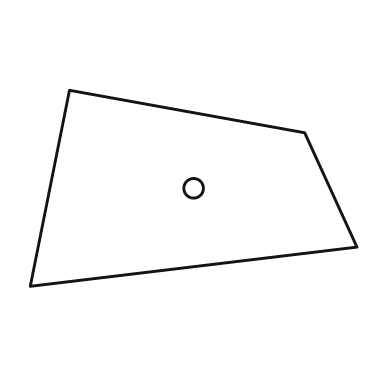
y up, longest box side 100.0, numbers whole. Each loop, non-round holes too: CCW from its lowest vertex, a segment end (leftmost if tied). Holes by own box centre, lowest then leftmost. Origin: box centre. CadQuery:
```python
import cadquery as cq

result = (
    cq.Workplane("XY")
    .moveTo(-50.0, -30.0)
    .lineTo(50.0, -18.0)
    .lineTo(34.0, 17.0)
    .lineTo(-38.0, 30.0)
    .close()
    .moveTo(0.0, 0.0)
    .circle(3.0)
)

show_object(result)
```